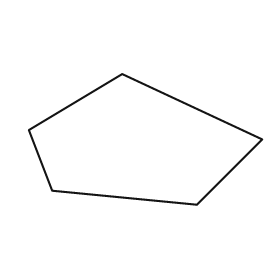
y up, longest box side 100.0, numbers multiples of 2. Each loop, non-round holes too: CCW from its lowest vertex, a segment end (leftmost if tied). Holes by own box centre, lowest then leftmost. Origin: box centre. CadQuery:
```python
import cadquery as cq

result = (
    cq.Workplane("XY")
    .moveTo(22.0, -28.0)
    .lineTo(50.0, 0.0)
    .lineTo(-10.0, 28.0)
    .lineTo(-50.0, 4.0)
    .lineTo(-40.0, -22.0)
    .close()
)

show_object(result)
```